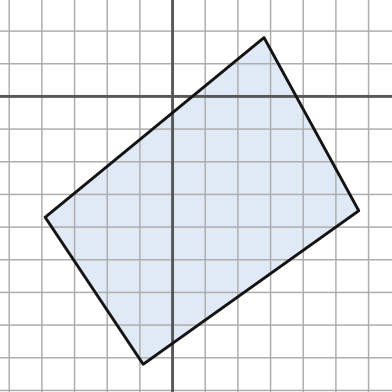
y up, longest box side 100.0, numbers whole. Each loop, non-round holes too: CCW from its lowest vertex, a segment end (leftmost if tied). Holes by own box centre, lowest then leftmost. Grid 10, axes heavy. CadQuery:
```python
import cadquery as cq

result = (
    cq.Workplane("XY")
    .moveTo(-9.0, -82.0)
    .lineTo(57.0, -35.0)
    .lineTo(28.0, 18.0)
    .lineTo(-39.0, -37.0)
    .close()
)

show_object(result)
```